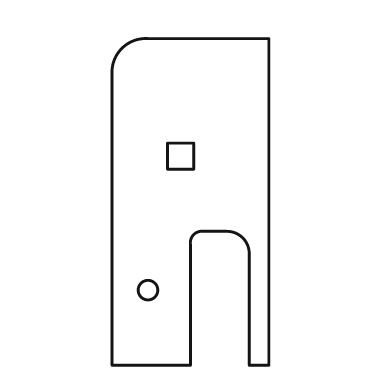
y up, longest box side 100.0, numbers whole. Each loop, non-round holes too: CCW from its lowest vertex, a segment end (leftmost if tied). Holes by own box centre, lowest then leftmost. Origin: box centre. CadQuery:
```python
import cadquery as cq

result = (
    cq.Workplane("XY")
    .moveTo(-24.0, -50.0)
    .lineTo(0.0, -50.0)
    .lineTo(0.0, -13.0)
    .threePointArc((1.0, -10.0), (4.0, -9.0))
    .lineTo(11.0, -9.0)
    .threePointArc((16.0, -11.0), (18.0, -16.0))
    .lineTo(18.0, -50.0)
    .lineTo(24.0, -50.0)
    .lineTo(24.0, 50.0)
    .lineTo(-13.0, 50.0)
    .threePointArc((-21.0, 47.0), (-24.0, 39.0))
    .close()
    .moveTo(-13.0, -27.0)
    .circle(3.0)
    .moveTo(-7.0, 10.0)
    .lineTo(1.0, 10.0)
    .lineTo(1.0, 18.0)
    .lineTo(-7.0, 18.0)
    .close()
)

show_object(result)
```